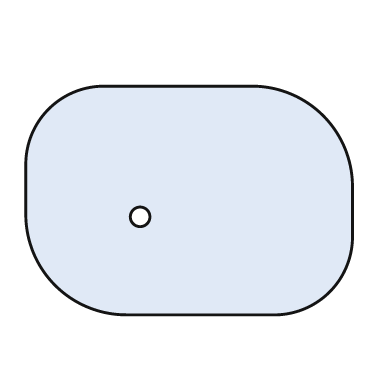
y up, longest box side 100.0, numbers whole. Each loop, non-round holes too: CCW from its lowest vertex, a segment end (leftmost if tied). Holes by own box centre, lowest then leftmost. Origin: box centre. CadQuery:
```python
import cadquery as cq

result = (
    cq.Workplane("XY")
    .moveTo(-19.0, -35.0)
    .lineTo(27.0, -35.0)
    .threePointArc((43.0, -28.0), (50.0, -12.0))
    .lineTo(50.0, 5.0)
    .threePointArc((41.0, 26.0), (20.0, 35.0))
    .lineTo(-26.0, 35.0)
    .threePointArc((-43.0, 28.0), (-50.0, 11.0))
    .lineTo(-50.0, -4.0)
    .threePointArc((-41.0, -26.0), (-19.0, -35.0))
    .close()
    .moveTo(-15.0, -5.0)
    .circle(3.0)
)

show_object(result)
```